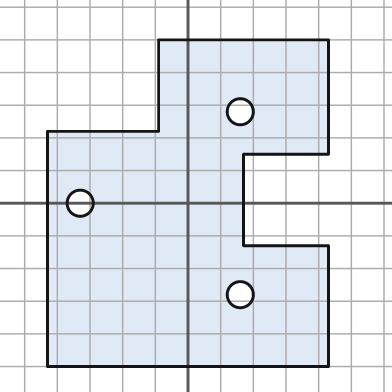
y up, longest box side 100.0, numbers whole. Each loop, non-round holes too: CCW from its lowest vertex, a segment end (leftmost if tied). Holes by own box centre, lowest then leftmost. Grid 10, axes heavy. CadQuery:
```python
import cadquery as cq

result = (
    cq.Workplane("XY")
    .moveTo(-43.0, -50.0)
    .lineTo(43.0, -50.0)
    .lineTo(43.0, -13.0)
    .lineTo(17.0, -13.0)
    .lineTo(17.0, 15.0)
    .lineTo(43.0, 15.0)
    .lineTo(43.0, 50.0)
    .lineTo(-9.0, 50.0)
    .lineTo(-9.0, 22.0)
    .lineTo(-43.0, 22.0)
    .close()
    .moveTo(16.0, -28.0)
    .circle(4.0)
    .moveTo(-33.0, 0.0)
    .circle(4.0)
    .moveTo(16.0, 28.0)
    .circle(4.0)
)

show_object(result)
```